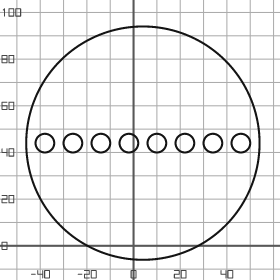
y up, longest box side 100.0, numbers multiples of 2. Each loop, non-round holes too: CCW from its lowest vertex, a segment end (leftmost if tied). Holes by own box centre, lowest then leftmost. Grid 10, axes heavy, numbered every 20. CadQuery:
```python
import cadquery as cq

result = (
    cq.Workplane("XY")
    .moveTo(4.0, 44.0)
    .circle(50.0)
    .moveTo(-38.0, 44.0)
    .circle(4.0)
    .moveTo(-26.0, 44.0)
    .circle(4.0)
    .moveTo(-14.0, 44.0)
    .circle(4.0)
    .moveTo(-2.0, 44.0)
    .circle(4.0)
    .moveTo(10.0, 44.0)
    .circle(4.0)
    .moveTo(22.0, 44.0)
    .circle(4.0)
    .moveTo(34.0, 44.0)
    .circle(4.0)
    .moveTo(46.0, 44.0)
    .circle(4.0)
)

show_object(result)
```